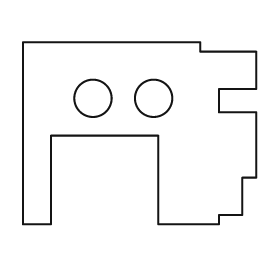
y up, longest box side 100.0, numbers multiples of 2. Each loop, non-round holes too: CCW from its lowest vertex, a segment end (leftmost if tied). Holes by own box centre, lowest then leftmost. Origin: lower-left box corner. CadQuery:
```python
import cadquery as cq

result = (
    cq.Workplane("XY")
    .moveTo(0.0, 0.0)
    .lineTo(12.0, 0.0)
    .lineTo(12.0, 38.0)
    .lineTo(58.0, 38.0)
    .lineTo(58.0, 0.0)
    .lineTo(84.0, 0.0)
    .lineTo(84.0, 4.0)
    .lineTo(94.0, 4.0)
    .lineTo(94.0, 20.0)
    .lineTo(100.0, 20.0)
    .lineTo(100.0, 48.0)
    .lineTo(84.0, 48.0)
    .lineTo(84.0, 58.0)
    .lineTo(100.0, 58.0)
    .lineTo(100.0, 74.0)
    .lineTo(76.0, 74.0)
    .lineTo(76.0, 78.0)
    .lineTo(0.0, 78.0)
    .close()
    .moveTo(30.0, 54.0)
    .circle(8.0)
    .moveTo(56.0, 54.0)
    .circle(8.0)
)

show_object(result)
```